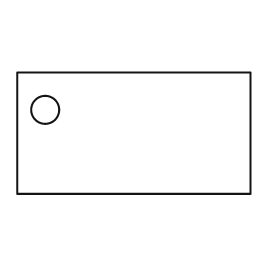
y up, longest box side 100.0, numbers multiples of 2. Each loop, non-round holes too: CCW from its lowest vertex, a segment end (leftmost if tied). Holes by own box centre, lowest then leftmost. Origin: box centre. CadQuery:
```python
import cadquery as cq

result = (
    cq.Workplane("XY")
    .moveTo(-50.0, -26.0)
    .lineTo(50.0, -26.0)
    .lineTo(50.0, 26.0)
    .lineTo(-50.0, 26.0)
    .close()
    .moveTo(-38.0, 10.0)
    .circle(6.0)
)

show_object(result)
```